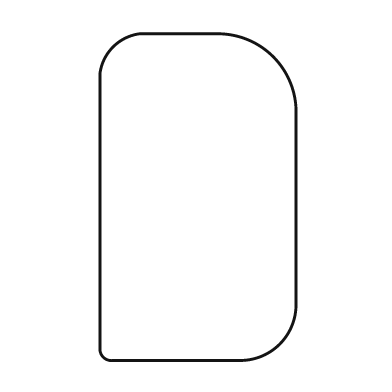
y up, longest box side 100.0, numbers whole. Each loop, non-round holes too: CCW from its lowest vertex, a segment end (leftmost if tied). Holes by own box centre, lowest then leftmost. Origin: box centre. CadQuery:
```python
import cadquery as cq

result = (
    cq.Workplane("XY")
    .moveTo(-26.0, -50.0)
    .lineTo(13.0, -50.0)
    .threePointArc((25.0, -45.0), (30.0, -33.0))
    .lineTo(30.0, 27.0)
    .threePointArc((23.0, 43.0), (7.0, 50.0))
    .lineTo(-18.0, 50.0)
    .threePointArc((-26.0, 46.0), (-30.0, 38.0))
    .lineTo(-30.0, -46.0)
    .threePointArc((-29.0, -49.0), (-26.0, -50.0))
    .close()
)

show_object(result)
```